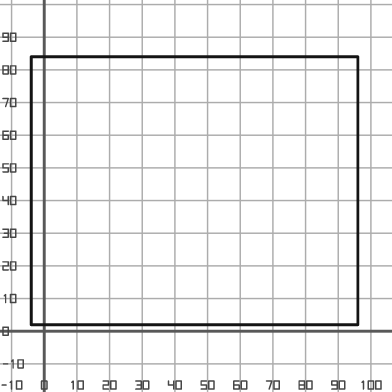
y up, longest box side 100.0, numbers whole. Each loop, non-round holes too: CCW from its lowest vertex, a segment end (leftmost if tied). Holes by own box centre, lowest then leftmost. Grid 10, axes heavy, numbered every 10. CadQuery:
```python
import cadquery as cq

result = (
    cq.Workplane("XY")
    .moveTo(-4.0, 2.0)
    .lineTo(96.0, 2.0)
    .lineTo(96.0, 84.0)
    .lineTo(-4.0, 84.0)
    .close()
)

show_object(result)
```